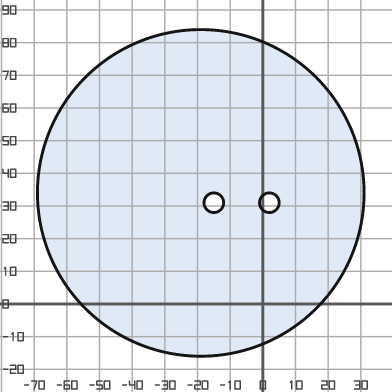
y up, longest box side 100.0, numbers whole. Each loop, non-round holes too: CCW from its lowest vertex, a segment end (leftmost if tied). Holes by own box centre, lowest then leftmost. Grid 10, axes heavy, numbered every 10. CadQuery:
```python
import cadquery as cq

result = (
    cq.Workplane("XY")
    .moveTo(-19.0, 34.0)
    .circle(50.0)
    .moveTo(-15.0, 31.0)
    .circle(3.0)
    .moveTo(2.0, 31.0)
    .circle(3.0)
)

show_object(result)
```